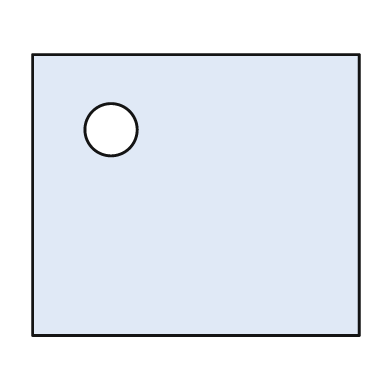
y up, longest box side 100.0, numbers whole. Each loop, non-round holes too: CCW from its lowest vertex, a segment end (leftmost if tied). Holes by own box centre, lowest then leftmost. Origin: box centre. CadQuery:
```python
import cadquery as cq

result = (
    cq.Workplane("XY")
    .moveTo(-50.0, -43.0)
    .lineTo(50.0, -43.0)
    .lineTo(50.0, 43.0)
    .lineTo(-50.0, 43.0)
    .close()
    .moveTo(-26.0, 20.0)
    .circle(8.0)
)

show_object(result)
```